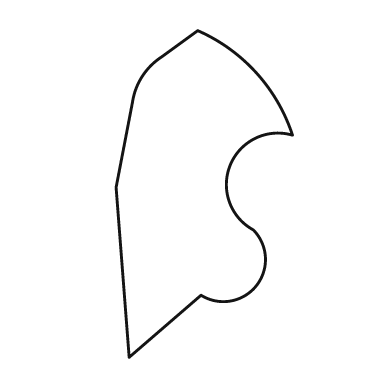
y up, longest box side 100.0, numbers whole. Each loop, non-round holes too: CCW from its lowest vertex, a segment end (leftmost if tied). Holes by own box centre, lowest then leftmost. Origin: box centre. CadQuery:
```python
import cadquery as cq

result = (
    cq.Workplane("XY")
    .moveTo(-23.0, -50.0)
    .lineTo(-1.0, -31.0)
    .threePointArc((16.0, -28.0), (15.0, -11.0))
    .threePointArc((8.0, 9.0), (27.0, 18.0))
    .threePointArc((16.0, 37.0), (-2.0, 50.0))
    .lineTo(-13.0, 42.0)
    .threePointArc((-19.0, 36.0), (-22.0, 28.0))
    .lineTo(-27.0, 2.0)
    .close()
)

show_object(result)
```